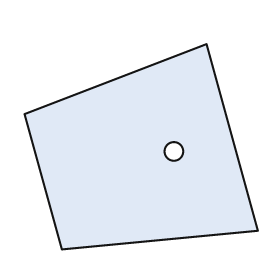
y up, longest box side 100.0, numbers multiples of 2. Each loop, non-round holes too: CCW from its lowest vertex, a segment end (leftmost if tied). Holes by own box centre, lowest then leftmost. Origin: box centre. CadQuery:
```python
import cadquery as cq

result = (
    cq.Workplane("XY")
    .moveTo(-34.0, -44.0)
    .lineTo(50.0, -36.0)
    .lineTo(28.0, 44.0)
    .lineTo(-50.0, 14.0)
    .close()
    .moveTo(14.0, -2.0)
    .circle(4.0)
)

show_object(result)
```